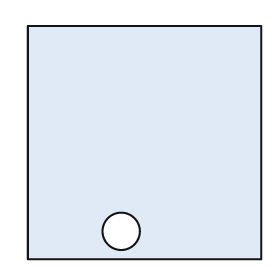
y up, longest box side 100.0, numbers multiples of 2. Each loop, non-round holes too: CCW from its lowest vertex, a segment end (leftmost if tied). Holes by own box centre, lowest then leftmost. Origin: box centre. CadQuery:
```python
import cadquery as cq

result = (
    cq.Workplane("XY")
    .moveTo(-50.0, -50.0)
    .lineTo(50.0, -50.0)
    .lineTo(50.0, 50.0)
    .lineTo(-50.0, 50.0)
    .close()
    .moveTo(-10.0, -38.0)
    .circle(8.0)
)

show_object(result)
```